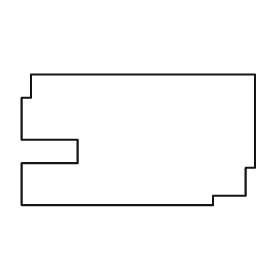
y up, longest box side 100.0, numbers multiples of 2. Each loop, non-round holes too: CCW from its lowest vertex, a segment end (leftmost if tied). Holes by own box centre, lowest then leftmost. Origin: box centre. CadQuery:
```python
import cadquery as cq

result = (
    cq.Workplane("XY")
    .moveTo(-50.0, -28.0)
    .lineTo(32.0, -28.0)
    .lineTo(32.0, -24.0)
    .lineTo(46.0, -24.0)
    .lineTo(46.0, -12.0)
    .lineTo(50.0, -12.0)
    .lineTo(50.0, 28.0)
    .lineTo(-46.0, 28.0)
    .lineTo(-46.0, 18.0)
    .lineTo(-50.0, 18.0)
    .lineTo(-50.0, 0.0)
    .lineTo(-26.0, 0.0)
    .lineTo(-26.0, -10.0)
    .lineTo(-50.0, -10.0)
    .close()
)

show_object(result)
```